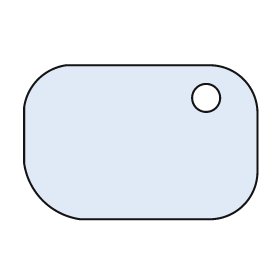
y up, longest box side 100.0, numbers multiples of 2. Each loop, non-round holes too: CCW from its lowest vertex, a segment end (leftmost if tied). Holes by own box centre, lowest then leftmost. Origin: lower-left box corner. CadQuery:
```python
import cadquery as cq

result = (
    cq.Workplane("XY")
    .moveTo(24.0, 0.0)
    .lineTo(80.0, 0.0)
    .threePointArc((94.0, 6.0), (100.0, 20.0))
    .lineTo(100.0, 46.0)
    .threePointArc((94.0, 60.0), (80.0, 66.0))
    .lineTo(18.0, 66.0)
    .threePointArc((6.0, 60.0), (0.0, 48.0))
    .lineTo(0.0, 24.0)
    .threePointArc((8.0, 8.0), (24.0, 0.0))
    .close()
    .moveTo(78.0, 52.0)
    .circle(6.0)
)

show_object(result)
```